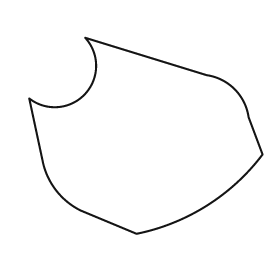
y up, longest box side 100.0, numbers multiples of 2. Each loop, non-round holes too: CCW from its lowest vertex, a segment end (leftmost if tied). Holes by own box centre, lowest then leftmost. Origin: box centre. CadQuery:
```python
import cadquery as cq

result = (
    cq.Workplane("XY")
    .moveTo(-4.0, -42.0)
    .threePointArc((26.0, -30.0), (50.0, -8.0))
    .lineTo(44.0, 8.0)
    .threePointArc((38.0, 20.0), (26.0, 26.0))
    .lineTo(-26.0, 42.0)
    .threePointArc((-26.0, 18.0), (-50.0, 16.0))
    .lineTo(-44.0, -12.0)
    .threePointArc((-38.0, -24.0), (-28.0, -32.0))
    .close()
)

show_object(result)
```